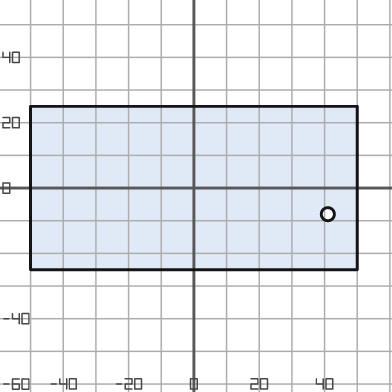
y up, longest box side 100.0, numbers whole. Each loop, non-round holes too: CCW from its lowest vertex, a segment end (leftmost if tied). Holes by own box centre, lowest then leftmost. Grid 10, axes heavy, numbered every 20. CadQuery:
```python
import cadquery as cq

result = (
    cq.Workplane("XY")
    .moveTo(-50.0, -25.0)
    .lineTo(50.0, -25.0)
    .lineTo(50.0, 25.0)
    .lineTo(-50.0, 25.0)
    .close()
    .moveTo(41.0, -8.0)
    .circle(2.0)
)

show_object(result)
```